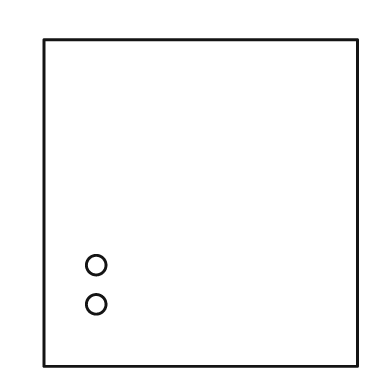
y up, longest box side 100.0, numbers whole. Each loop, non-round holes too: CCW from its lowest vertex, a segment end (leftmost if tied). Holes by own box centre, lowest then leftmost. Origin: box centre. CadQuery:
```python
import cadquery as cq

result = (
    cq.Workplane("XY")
    .moveTo(-48.0, -50.0)
    .lineTo(48.0, -50.0)
    .lineTo(48.0, 50.0)
    .lineTo(-48.0, 50.0)
    .close()
    .moveTo(-32.0, -31.0)
    .circle(3.0)
    .moveTo(-32.0, -19.0)
    .circle(3.0)
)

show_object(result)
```